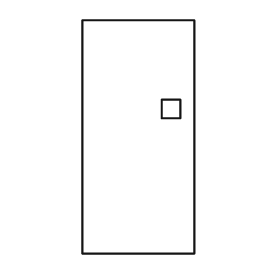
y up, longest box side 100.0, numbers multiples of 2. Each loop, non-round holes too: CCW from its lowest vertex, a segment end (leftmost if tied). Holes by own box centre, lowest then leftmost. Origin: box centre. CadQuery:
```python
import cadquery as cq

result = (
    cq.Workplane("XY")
    .moveTo(-24.0, -50.0)
    .lineTo(24.0, -50.0)
    .lineTo(24.0, 50.0)
    .lineTo(-24.0, 50.0)
    .close()
    .moveTo(10.0, 8.0)
    .lineTo(18.0, 8.0)
    .lineTo(18.0, 16.0)
    .lineTo(10.0, 16.0)
    .close()
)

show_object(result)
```